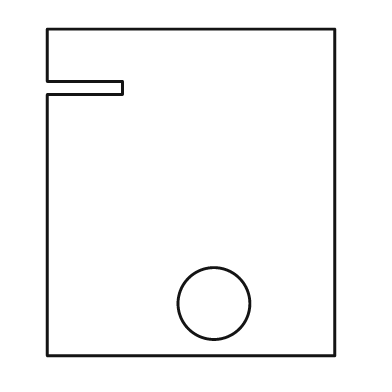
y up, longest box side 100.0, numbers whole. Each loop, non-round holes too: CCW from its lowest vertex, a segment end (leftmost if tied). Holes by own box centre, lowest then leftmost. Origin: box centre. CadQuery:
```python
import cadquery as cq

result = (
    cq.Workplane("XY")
    .moveTo(-44.0, -50.0)
    .lineTo(44.0, -50.0)
    .lineTo(44.0, 50.0)
    .lineTo(-44.0, 50.0)
    .lineTo(-44.0, 34.0)
    .lineTo(-21.0, 34.0)
    .lineTo(-21.0, 30.0)
    .lineTo(-44.0, 30.0)
    .close()
    .moveTo(7.0, -34.0)
    .circle(11.0)
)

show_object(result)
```